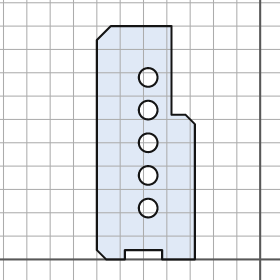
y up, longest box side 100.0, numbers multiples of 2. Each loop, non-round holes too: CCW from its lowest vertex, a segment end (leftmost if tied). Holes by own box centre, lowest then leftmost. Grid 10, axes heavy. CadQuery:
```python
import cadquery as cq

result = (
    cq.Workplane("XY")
    .moveTo(-66.0, 0.0)
    .lineTo(-58.0, 0.0)
    .lineTo(-58.0, 4.0)
    .lineTo(-42.0, 4.0)
    .lineTo(-42.0, 0.0)
    .lineTo(-28.0, 0.0)
    .lineTo(-28.0, 58.0)
    .lineTo(-32.0, 62.0)
    .lineTo(-38.0, 62.0)
    .lineTo(-38.0, 100.0)
    .lineTo(-64.0, 100.0)
    .lineTo(-70.0, 94.0)
    .lineTo(-70.0, 4.0)
    .close()
    .moveTo(-48.0, 22.0)
    .circle(4.0)
    .moveTo(-48.0, 36.0)
    .circle(4.0)
    .moveTo(-48.0, 50.0)
    .circle(4.0)
    .moveTo(-48.0, 64.0)
    .circle(4.0)
    .moveTo(-48.0, 78.0)
    .circle(4.0)
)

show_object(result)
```